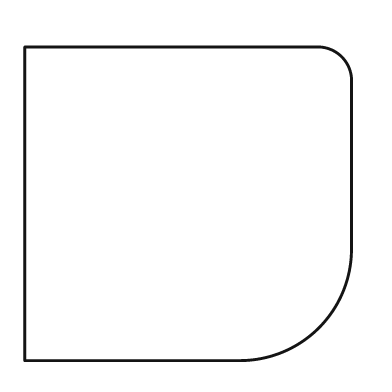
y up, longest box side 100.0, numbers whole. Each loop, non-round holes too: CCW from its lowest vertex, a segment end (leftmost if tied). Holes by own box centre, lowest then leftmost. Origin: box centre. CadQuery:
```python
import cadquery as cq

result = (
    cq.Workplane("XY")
    .moveTo(-50.0, -48.0)
    .lineTo(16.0, -48.0)
    .threePointArc((40.0, -38.0), (50.0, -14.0))
    .lineTo(50.0, 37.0)
    .threePointArc((47.0, 45.0), (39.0, 48.0))
    .lineTo(-50.0, 48.0)
    .close()
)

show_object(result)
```